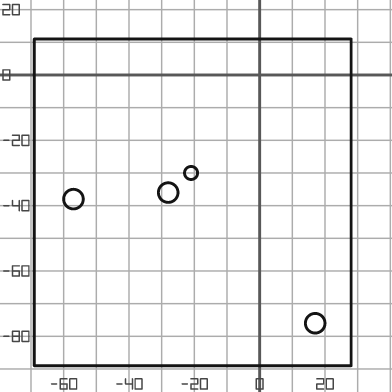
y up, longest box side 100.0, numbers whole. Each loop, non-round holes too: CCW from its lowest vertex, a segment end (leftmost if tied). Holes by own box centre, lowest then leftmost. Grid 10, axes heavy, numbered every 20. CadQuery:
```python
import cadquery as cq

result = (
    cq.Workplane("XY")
    .moveTo(-69.0, -89.0)
    .lineTo(28.0, -89.0)
    .lineTo(28.0, 11.0)
    .lineTo(-69.0, 11.0)
    .close()
    .moveTo(17.0, -76.0)
    .circle(3.0)
    .moveTo(-57.0, -38.0)
    .circle(3.0)
    .moveTo(-28.0, -36.0)
    .circle(3.0)
    .moveTo(-21.0, -30.0)
    .circle(2.0)
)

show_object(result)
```